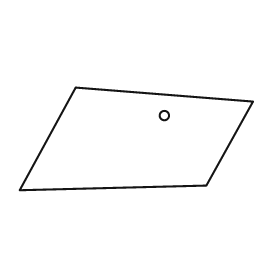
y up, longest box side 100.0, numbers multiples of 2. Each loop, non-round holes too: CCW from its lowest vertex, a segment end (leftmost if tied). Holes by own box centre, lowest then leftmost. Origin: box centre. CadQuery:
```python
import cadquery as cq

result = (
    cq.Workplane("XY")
    .moveTo(-50.0, -22.0)
    .lineTo(30.0, -20.0)
    .lineTo(50.0, 16.0)
    .lineTo(-26.0, 22.0)
    .close()
    .moveTo(12.0, 10.0)
    .circle(2.0)
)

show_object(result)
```